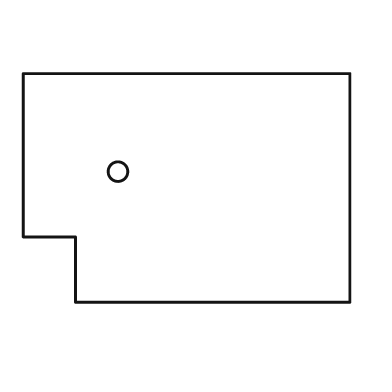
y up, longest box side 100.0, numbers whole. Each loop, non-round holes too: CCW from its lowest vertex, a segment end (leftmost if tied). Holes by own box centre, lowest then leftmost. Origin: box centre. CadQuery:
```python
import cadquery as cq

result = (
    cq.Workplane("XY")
    .moveTo(-34.0, -35.0)
    .lineTo(50.0, -35.0)
    .lineTo(50.0, 35.0)
    .lineTo(-50.0, 35.0)
    .lineTo(-50.0, -15.0)
    .lineTo(-34.0, -15.0)
    .close()
    .moveTo(-21.0, 5.0)
    .circle(3.0)
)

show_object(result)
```